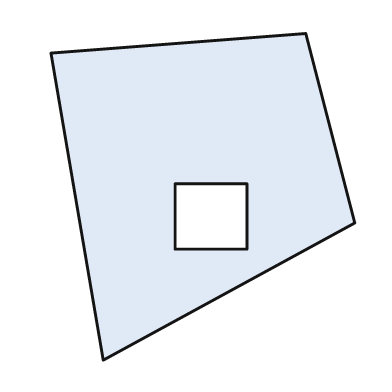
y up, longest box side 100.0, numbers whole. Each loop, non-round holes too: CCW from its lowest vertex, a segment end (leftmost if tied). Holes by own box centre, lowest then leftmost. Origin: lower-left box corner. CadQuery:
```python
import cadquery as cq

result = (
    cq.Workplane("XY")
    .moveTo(16.0, 0.0)
    .lineTo(93.0, 42.0)
    .lineTo(78.0, 100.0)
    .lineTo(0.0, 94.0)
    .close()
    .moveTo(38.0, 34.0)
    .lineTo(60.0, 34.0)
    .lineTo(60.0, 54.0)
    .lineTo(38.0, 54.0)
    .close()
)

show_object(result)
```